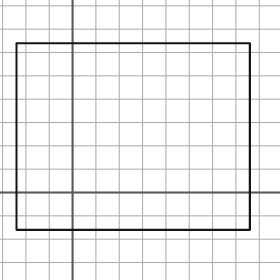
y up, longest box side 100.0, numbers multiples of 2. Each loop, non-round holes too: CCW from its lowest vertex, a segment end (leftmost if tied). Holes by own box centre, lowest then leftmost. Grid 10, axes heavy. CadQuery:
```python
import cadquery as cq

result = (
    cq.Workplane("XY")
    .moveTo(-24.0, -16.0)
    .lineTo(76.0, -16.0)
    .lineTo(76.0, 64.0)
    .lineTo(-24.0, 64.0)
    .close()
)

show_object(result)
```